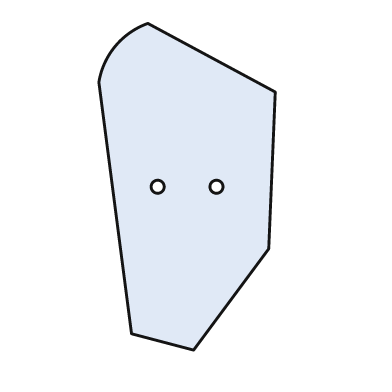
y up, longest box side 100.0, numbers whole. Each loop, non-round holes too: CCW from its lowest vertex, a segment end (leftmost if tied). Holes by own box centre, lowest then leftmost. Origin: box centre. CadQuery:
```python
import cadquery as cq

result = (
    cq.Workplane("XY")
    .moveTo(2.0, -50.0)
    .lineTo(25.0, -19.0)
    .lineTo(27.0, 29.0)
    .lineTo(-12.0, 50.0)
    .threePointArc((-22.0, 43.0), (-27.0, 32.0))
    .lineTo(-17.0, -45.0)
    .close()
    .moveTo(-9.0, 0.0)
    .circle(2.0)
    .moveTo(9.0, 0.0)
    .circle(2.0)
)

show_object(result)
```